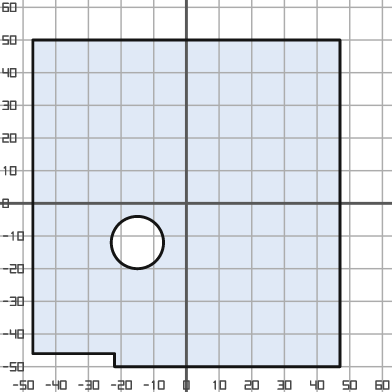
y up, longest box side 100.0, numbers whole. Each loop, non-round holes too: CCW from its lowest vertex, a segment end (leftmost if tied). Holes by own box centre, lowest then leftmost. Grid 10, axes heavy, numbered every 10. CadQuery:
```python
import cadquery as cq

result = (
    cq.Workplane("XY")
    .moveTo(-22.0, -50.0)
    .lineTo(47.0, -50.0)
    .lineTo(47.0, 50.0)
    .lineTo(-47.0, 50.0)
    .lineTo(-47.0, -46.0)
    .lineTo(-22.0, -46.0)
    .close()
    .moveTo(-15.0, -12.0)
    .circle(8.0)
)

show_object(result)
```